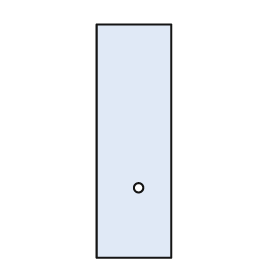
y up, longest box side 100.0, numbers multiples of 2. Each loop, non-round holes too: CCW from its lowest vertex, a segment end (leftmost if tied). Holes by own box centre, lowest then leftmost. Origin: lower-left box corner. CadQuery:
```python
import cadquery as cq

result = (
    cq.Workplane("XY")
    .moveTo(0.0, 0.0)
    .lineTo(32.0, 0.0)
    .lineTo(32.0, 100.0)
    .lineTo(0.0, 100.0)
    .close()
    .moveTo(18.0, 30.0)
    .circle(2.0)
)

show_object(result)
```